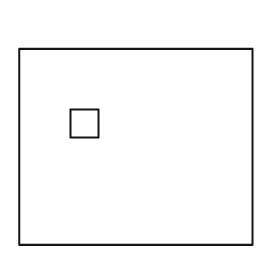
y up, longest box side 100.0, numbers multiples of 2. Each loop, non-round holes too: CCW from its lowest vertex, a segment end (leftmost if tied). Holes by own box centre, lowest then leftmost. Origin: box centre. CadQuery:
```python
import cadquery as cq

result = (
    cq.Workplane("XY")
    .moveTo(-50.0, -42.0)
    .lineTo(50.0, -42.0)
    .lineTo(50.0, 42.0)
    .lineTo(-50.0, 42.0)
    .close()
    .moveTo(-28.0, 4.0)
    .lineTo(-16.0, 4.0)
    .lineTo(-16.0, 16.0)
    .lineTo(-28.0, 16.0)
    .close()
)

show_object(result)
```